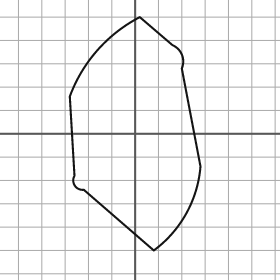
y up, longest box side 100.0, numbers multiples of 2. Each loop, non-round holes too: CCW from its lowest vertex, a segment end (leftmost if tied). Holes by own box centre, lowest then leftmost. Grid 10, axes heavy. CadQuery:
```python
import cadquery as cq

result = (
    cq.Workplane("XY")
    .moveTo(8.0, -50.0)
    .threePointArc((22.0, -34.0), (28.0, -14.0))
    .lineTo(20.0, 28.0)
    .threePointArc((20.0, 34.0), (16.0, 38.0))
    .lineTo(2.0, 50.0)
    .threePointArc((-16.0, 36.0), (-28.0, 16.0))
    .lineTo(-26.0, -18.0)
    .threePointArc((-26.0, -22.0), (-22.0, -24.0))
    .close()
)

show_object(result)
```